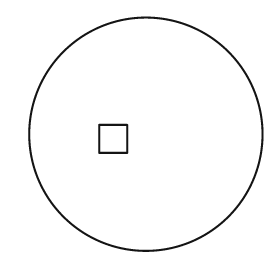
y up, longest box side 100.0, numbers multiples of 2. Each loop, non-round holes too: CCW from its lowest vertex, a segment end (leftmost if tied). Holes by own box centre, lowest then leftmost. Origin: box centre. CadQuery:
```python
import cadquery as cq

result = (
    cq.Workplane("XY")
    .moveTo(0.0, 0.0)
    .circle(50.0)
    .moveTo(-20.0, -8.0)
    .lineTo(-8.0, -8.0)
    .lineTo(-8.0, 4.0)
    .lineTo(-20.0, 4.0)
    .close()
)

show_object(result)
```